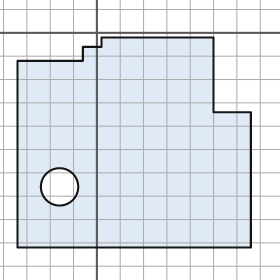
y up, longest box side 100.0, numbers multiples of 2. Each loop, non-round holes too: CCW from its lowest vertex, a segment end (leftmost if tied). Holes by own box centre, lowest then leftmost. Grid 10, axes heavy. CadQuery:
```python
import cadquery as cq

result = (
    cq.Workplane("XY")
    .moveTo(-34.0, -92.0)
    .lineTo(66.0, -92.0)
    .lineTo(66.0, -34.0)
    .lineTo(50.0, -34.0)
    .lineTo(50.0, -2.0)
    .lineTo(2.0, -2.0)
    .lineTo(2.0, -6.0)
    .lineTo(-6.0, -6.0)
    .lineTo(-6.0, -12.0)
    .lineTo(-34.0, -12.0)
    .close()
    .moveTo(-16.0, -66.0)
    .circle(8.0)
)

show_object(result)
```